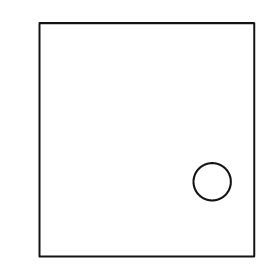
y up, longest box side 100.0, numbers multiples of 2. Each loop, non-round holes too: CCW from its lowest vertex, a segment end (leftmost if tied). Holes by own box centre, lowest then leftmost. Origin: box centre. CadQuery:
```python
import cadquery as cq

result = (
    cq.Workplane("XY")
    .moveTo(-46.0, -50.0)
    .lineTo(46.0, -50.0)
    .lineTo(46.0, 50.0)
    .lineTo(-46.0, 50.0)
    .close()
    .moveTo(28.0, -18.0)
    .circle(8.0)
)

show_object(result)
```